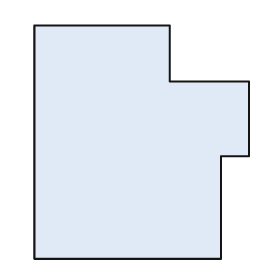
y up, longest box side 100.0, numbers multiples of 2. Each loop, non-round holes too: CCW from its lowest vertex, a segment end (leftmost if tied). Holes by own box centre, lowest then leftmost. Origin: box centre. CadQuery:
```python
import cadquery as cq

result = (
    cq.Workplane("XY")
    .moveTo(-46.0, -50.0)
    .lineTo(34.0, -50.0)
    .lineTo(34.0, -6.0)
    .lineTo(46.0, -6.0)
    .lineTo(46.0, 26.0)
    .lineTo(12.0, 26.0)
    .lineTo(12.0, 50.0)
    .lineTo(-46.0, 50.0)
    .close()
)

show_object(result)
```